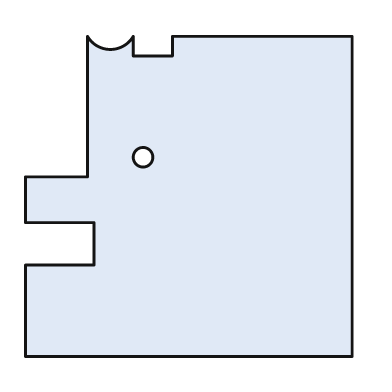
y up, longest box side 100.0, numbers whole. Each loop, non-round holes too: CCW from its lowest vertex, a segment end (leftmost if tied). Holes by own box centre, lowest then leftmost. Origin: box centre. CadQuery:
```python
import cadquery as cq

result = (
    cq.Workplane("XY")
    .moveTo(-50.0, -49.0)
    .lineTo(50.0, -49.0)
    .lineTo(50.0, 49.0)
    .lineTo(-5.0, 49.0)
    .lineTo(-5.0, 43.0)
    .lineTo(-17.0, 43.0)
    .lineTo(-17.0, 49.0)
    .threePointArc((-24.0, 45.0), (-31.0, 49.0))
    .lineTo(-31.0, 6.0)
    .lineTo(-50.0, 6.0)
    .lineTo(-50.0, -8.0)
    .lineTo(-29.0, -8.0)
    .lineTo(-29.0, -21.0)
    .lineTo(-50.0, -21.0)
    .close()
    .moveTo(-14.0, 12.0)
    .circle(3.0)
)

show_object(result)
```